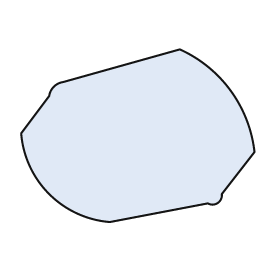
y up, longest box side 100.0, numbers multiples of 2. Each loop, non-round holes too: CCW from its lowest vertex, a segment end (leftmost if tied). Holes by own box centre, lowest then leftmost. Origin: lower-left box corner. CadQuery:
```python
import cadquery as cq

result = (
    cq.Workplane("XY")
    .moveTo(38.0, 0.0)
    .lineTo(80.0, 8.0)
    .threePointArc((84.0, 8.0), (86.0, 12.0))
    .lineTo(100.0, 30.0)
    .threePointArc((90.0, 56.0), (68.0, 74.0))
    .lineTo(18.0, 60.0)
    .threePointArc((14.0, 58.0), (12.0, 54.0))
    .lineTo(0.0, 38.0)
    .threePointArc((12.0, 12.0), (38.0, 0.0))
    .close()
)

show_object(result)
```